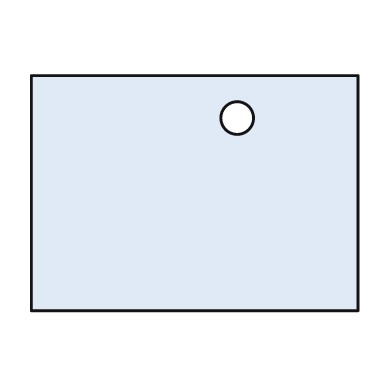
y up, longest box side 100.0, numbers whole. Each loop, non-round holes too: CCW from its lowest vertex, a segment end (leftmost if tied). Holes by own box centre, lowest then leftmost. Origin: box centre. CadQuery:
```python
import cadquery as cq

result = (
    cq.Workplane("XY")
    .moveTo(-50.0, -36.0)
    .lineTo(50.0, -36.0)
    .lineTo(50.0, 36.0)
    .lineTo(-50.0, 36.0)
    .close()
    .moveTo(13.0, 23.0)
    .circle(5.0)
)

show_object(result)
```